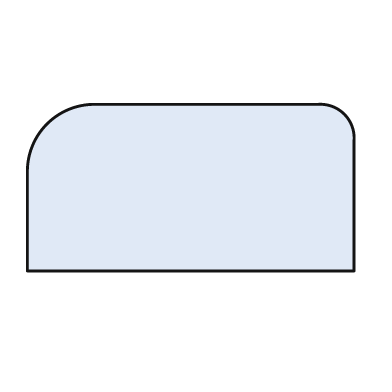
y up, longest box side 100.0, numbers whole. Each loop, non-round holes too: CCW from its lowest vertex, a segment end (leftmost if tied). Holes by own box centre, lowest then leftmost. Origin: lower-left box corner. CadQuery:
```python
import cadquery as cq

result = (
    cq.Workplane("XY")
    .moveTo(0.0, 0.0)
    .lineTo(100.0, 0.0)
    .lineTo(100.0, 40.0)
    .threePointArc((97.0, 48.0), (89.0, 51.0))
    .lineTo(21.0, 51.0)
    .threePointArc((6.0, 45.0), (0.0, 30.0))
    .close()
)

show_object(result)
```